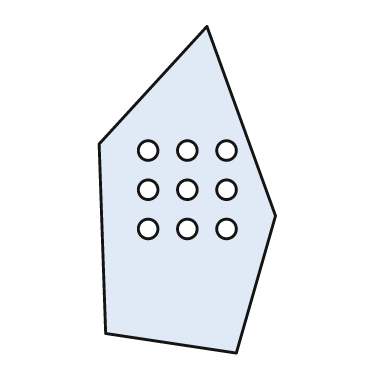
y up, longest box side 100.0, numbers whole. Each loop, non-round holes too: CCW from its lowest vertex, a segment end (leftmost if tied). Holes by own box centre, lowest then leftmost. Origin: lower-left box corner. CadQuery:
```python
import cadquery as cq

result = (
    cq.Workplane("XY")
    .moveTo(42.0, 0.0)
    .lineTo(54.0, 42.0)
    .lineTo(33.0, 100.0)
    .lineTo(0.0, 64.0)
    .lineTo(2.0, 6.0)
    .close()
    .moveTo(15.0, 38.0)
    .circle(3.0)
    .moveTo(27.0, 38.0)
    .circle(3.0)
    .moveTo(39.0, 38.0)
    .circle(3.0)
    .moveTo(15.0, 50.0)
    .circle(3.0)
    .moveTo(27.0, 50.0)
    .circle(3.0)
    .moveTo(39.0, 50.0)
    .circle(3.0)
    .moveTo(15.0, 62.0)
    .circle(3.0)
    .moveTo(27.0, 62.0)
    .circle(3.0)
    .moveTo(39.0, 62.0)
    .circle(3.0)
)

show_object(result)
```